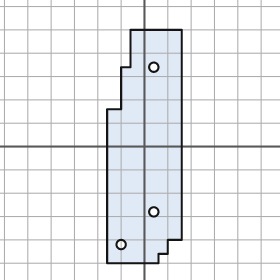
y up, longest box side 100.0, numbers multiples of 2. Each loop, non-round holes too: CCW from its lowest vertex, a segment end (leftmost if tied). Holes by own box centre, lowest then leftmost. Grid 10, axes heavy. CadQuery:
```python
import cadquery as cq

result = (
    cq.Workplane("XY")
    .moveTo(-16.0, -50.0)
    .lineTo(6.0, -50.0)
    .lineTo(6.0, -46.0)
    .lineTo(10.0, -46.0)
    .lineTo(10.0, -40.0)
    .lineTo(16.0, -40.0)
    .lineTo(16.0, 50.0)
    .lineTo(-6.0, 50.0)
    .lineTo(-6.0, 34.0)
    .lineTo(-10.0, 34.0)
    .lineTo(-10.0, 16.0)
    .lineTo(-16.0, 16.0)
    .close()
    .moveTo(-10.0, -42.0)
    .circle(2.0)
    .moveTo(4.0, -28.0)
    .circle(2.0)
    .moveTo(4.0, 34.0)
    .circle(2.0)
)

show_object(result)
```